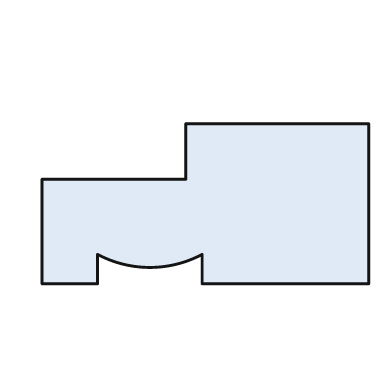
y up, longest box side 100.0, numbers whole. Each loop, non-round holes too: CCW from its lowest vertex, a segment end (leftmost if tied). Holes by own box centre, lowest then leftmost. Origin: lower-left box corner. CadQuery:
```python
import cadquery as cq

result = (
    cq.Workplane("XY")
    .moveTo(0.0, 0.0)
    .lineTo(17.0, 0.0)
    .lineTo(17.0, 9.0)
    .threePointArc((33.0, 5.0), (49.0, 9.0))
    .lineTo(49.0, 0.0)
    .lineTo(100.0, 0.0)
    .lineTo(100.0, 49.0)
    .lineTo(44.0, 49.0)
    .lineTo(44.0, 32.0)
    .lineTo(0.0, 32.0)
    .close()
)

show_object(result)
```